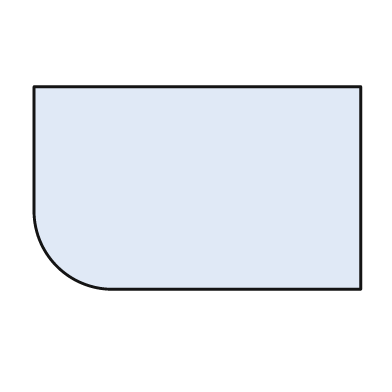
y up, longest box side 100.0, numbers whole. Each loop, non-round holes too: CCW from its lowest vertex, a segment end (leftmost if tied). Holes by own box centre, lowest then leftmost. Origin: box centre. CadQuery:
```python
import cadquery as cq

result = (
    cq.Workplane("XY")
    .moveTo(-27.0, -31.0)
    .lineTo(50.0, -31.0)
    .lineTo(50.0, 31.0)
    .lineTo(-50.0, 31.0)
    .lineTo(-50.0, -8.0)
    .threePointArc((-43.0, -24.0), (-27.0, -31.0))
    .close()
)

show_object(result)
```